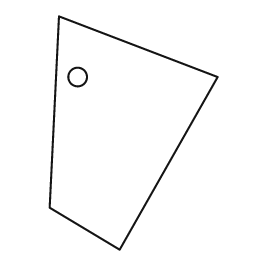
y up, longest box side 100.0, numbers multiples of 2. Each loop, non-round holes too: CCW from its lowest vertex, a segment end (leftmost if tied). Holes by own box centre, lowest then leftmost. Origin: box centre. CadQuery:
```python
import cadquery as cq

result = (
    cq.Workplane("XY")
    .moveTo(-6.0, -50.0)
    .lineTo(36.0, 24.0)
    .lineTo(-32.0, 50.0)
    .lineTo(-36.0, -32.0)
    .close()
    .moveTo(-24.0, 24.0)
    .circle(4.0)
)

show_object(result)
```